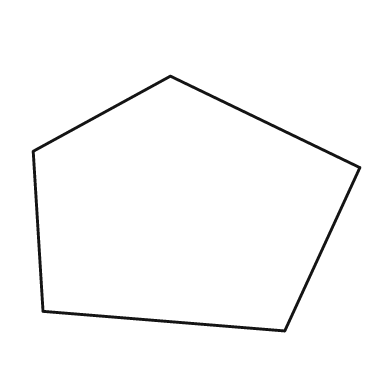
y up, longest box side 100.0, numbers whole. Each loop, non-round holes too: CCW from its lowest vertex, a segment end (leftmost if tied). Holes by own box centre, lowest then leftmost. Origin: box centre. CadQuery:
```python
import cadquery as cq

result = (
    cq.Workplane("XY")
    .moveTo(27.0, -39.0)
    .lineTo(50.0, 11.0)
    .lineTo(-8.0, 39.0)
    .lineTo(-50.0, 16.0)
    .lineTo(-47.0, -33.0)
    .close()
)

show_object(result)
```